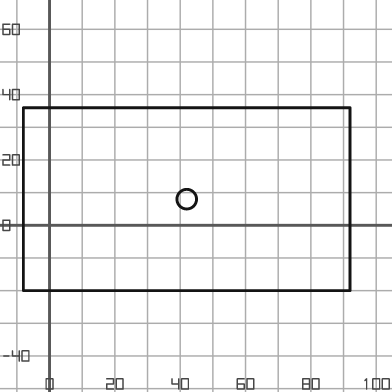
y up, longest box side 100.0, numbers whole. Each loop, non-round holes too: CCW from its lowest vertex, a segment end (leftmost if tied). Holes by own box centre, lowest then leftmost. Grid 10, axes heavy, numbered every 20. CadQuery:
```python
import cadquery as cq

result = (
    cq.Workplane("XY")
    .moveTo(-8.0, -20.0)
    .lineTo(92.0, -20.0)
    .lineTo(92.0, 36.0)
    .lineTo(-8.0, 36.0)
    .close()
    .moveTo(42.0, 8.0)
    .circle(3.0)
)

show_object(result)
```